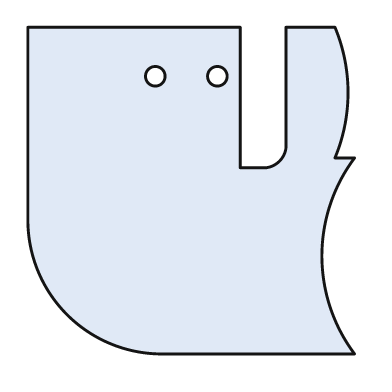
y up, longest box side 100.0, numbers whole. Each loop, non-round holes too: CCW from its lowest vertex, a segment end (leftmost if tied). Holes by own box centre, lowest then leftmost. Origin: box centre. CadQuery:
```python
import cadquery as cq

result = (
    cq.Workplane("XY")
    .moveTo(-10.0, -50.0)
    .lineTo(50.0, -50.0)
    .threePointArc((40.0, -20.0), (50.0, 10.0))
    .lineTo(44.0, 10.0)
    .threePointArc((48.0, 30.0), (44.0, 50.0))
    .lineTo(29.0, 50.0)
    .lineTo(29.0, 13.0)
    .threePointArc((27.0, 9.0), (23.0, 7.0))
    .lineTo(15.0, 7.0)
    .lineTo(15.0, 50.0)
    .lineTo(-50.0, 50.0)
    .lineTo(-50.0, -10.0)
    .threePointArc((-38.0, -38.0), (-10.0, -50.0))
    .close()
    .moveTo(-11.0, 35.0)
    .circle(3.0)
    .moveTo(8.0, 35.0)
    .circle(3.0)
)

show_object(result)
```